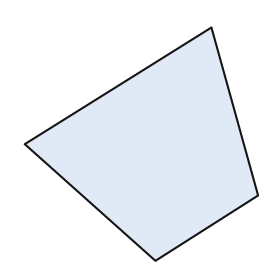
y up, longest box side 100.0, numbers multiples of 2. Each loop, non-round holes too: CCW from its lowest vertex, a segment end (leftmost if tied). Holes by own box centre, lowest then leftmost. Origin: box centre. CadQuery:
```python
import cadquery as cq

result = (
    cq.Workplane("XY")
    .moveTo(6.0, -50.0)
    .lineTo(50.0, -22.0)
    .lineTo(30.0, 50.0)
    .lineTo(-50.0, 0.0)
    .close()
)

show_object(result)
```